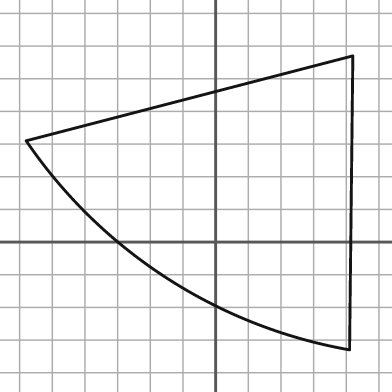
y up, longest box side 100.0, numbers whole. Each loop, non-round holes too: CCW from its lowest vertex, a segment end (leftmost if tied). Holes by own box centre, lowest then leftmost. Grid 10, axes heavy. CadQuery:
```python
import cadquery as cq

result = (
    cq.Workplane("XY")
    .moveTo(41.0, -33.0)
    .lineTo(42.0, 57.0)
    .lineTo(-58.0, 31.0)
    .threePointArc((-15.0, -11.0), (41.0, -33.0))
    .close()
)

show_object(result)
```